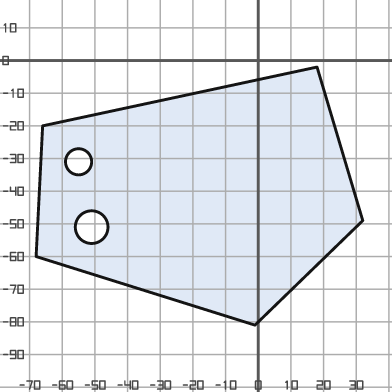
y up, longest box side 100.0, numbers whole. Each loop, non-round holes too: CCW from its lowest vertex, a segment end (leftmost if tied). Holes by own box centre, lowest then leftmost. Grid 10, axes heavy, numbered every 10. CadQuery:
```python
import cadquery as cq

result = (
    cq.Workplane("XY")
    .moveTo(-1.0, -81.0)
    .lineTo(32.0, -49.0)
    .lineTo(18.0, -2.0)
    .lineTo(-66.0, -20.0)
    .lineTo(-68.0, -60.0)
    .close()
    .moveTo(-51.0, -51.0)
    .circle(5.0)
    .moveTo(-55.0, -31.0)
    .circle(4.0)
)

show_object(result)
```